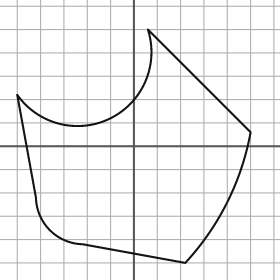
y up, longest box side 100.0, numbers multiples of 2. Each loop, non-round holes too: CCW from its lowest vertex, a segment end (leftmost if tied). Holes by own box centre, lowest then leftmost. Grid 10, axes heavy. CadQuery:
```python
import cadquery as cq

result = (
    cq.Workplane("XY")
    .moveTo(22.0, -50.0)
    .threePointArc((40.0, -24.0), (50.0, 6.0))
    .lineTo(6.0, 50.0)
    .threePointArc((-10.0, 12.0), (-50.0, 22.0))
    .lineTo(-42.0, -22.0)
    .threePointArc((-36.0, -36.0), (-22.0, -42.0))
    .close()
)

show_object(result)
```